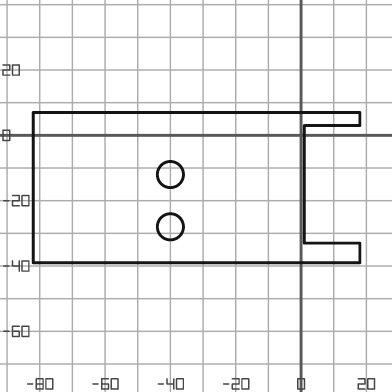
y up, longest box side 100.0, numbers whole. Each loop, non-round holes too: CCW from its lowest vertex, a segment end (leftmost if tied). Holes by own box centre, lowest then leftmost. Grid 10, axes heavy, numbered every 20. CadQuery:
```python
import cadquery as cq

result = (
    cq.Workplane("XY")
    .moveTo(-82.0, -39.0)
    .lineTo(18.0, -39.0)
    .lineTo(18.0, -33.0)
    .lineTo(1.0, -33.0)
    .lineTo(1.0, 3.0)
    .lineTo(18.0, 3.0)
    .lineTo(18.0, 7.0)
    .lineTo(-82.0, 7.0)
    .close()
    .moveTo(-40.0, -28.0)
    .circle(4.0)
    .moveTo(-40.0, -12.0)
    .circle(4.0)
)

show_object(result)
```